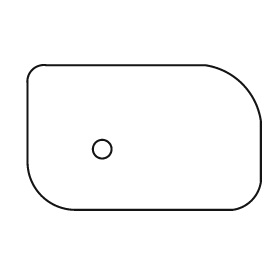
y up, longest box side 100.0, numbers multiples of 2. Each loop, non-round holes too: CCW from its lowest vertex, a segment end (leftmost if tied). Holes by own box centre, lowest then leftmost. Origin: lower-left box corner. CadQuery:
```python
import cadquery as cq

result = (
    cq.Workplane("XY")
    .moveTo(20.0, 0.0)
    .lineTo(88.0, 0.0)
    .threePointArc((96.0, 4.0), (100.0, 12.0))
    .lineTo(100.0, 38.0)
    .threePointArc((92.0, 54.0), (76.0, 62.0))
    .lineTo(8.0, 62.0)
    .threePointArc((2.0, 60.0), (0.0, 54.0))
    .lineTo(0.0, 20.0)
    .threePointArc((6.0, 6.0), (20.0, 0.0))
    .close()
    .moveTo(32.0, 26.0)
    .circle(4.0)
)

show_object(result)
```